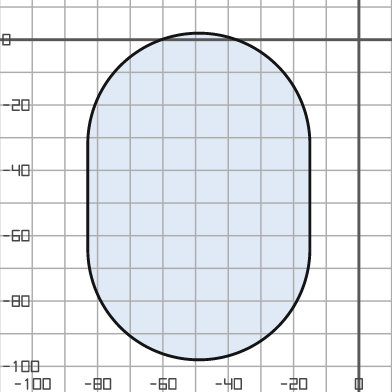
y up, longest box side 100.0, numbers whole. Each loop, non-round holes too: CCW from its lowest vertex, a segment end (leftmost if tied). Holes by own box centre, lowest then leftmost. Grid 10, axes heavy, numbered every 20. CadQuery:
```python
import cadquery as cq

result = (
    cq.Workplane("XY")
    .moveTo(-83.0, -64.0)
    .threePointArc((-49.0, -98.0), (-15.0, -64.0))
    .lineTo(-15.0, -32.0)
    .threePointArc((-49.0, 2.0), (-83.0, -32.0))
    .close()
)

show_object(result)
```